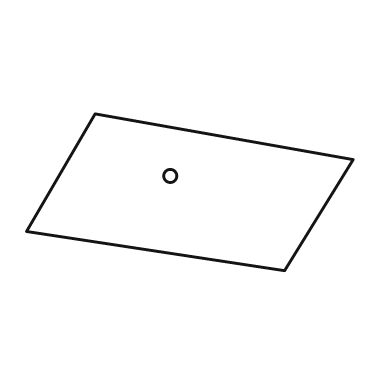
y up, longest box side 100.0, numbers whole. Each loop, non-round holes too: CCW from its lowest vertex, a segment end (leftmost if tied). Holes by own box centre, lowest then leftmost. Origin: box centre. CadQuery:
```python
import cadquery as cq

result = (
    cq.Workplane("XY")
    .moveTo(29.0, -24.0)
    .lineTo(50.0, 10.0)
    .lineTo(-29.0, 24.0)
    .lineTo(-50.0, -12.0)
    .close()
    .moveTo(-6.0, 5.0)
    .circle(2.0)
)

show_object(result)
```